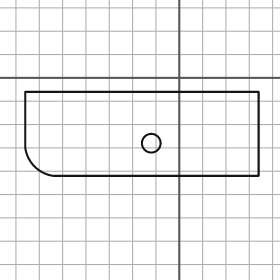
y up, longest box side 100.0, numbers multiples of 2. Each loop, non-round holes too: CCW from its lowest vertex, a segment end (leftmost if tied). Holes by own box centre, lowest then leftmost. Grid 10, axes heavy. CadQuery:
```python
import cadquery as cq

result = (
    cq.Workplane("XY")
    .moveTo(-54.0, -42.0)
    .lineTo(34.0, -42.0)
    .lineTo(34.0, -6.0)
    .lineTo(-66.0, -6.0)
    .lineTo(-66.0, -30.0)
    .threePointArc((-62.0, -38.0), (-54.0, -42.0))
    .close()
    .moveTo(-12.0, -28.0)
    .circle(4.0)
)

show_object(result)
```